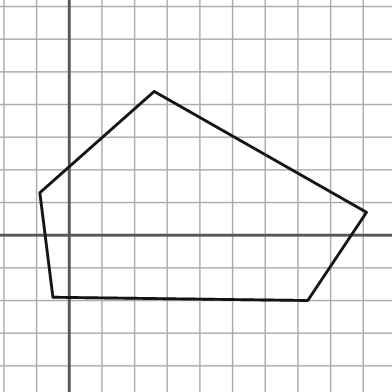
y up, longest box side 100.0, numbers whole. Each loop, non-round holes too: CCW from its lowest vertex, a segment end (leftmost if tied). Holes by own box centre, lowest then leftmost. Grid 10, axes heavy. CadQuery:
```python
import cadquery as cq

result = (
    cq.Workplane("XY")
    .moveTo(73.0, -20.0)
    .lineTo(91.0, 7.0)
    .lineTo(26.0, 44.0)
    .lineTo(-9.0, 13.0)
    .lineTo(-5.0, -19.0)
    .close()
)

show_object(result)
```